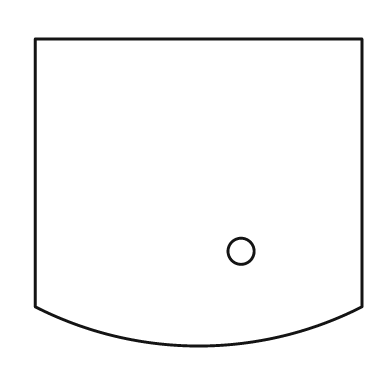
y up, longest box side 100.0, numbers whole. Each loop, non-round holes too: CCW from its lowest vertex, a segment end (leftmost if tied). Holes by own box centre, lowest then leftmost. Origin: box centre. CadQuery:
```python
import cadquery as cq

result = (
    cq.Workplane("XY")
    .moveTo(-50.0, -35.0)
    .threePointArc((0.0, -47.0), (50.0, -35.0))
    .lineTo(50.0, 47.0)
    .lineTo(-50.0, 47.0)
    .close()
    .moveTo(13.0, -18.0)
    .circle(4.0)
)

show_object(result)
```